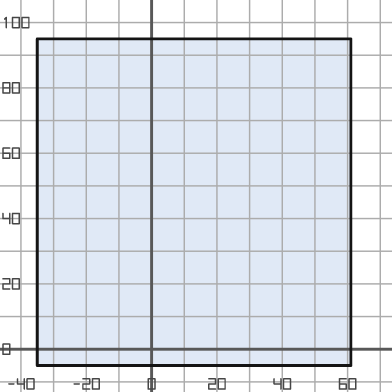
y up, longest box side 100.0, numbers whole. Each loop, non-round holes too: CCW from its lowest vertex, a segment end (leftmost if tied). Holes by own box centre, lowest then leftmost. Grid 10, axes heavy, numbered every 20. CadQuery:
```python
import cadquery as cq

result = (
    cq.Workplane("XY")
    .moveTo(-35.0, -5.0)
    .lineTo(61.0, -5.0)
    .lineTo(61.0, 95.0)
    .lineTo(-35.0, 95.0)
    .close()
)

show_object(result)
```